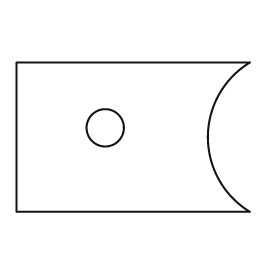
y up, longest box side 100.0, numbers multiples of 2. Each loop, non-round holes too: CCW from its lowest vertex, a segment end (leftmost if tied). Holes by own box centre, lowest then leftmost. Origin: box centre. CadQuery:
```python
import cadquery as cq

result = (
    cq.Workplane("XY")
    .moveTo(-50.0, -32.0)
    .lineTo(50.0, -32.0)
    .threePointArc((32.0, 0.0), (50.0, 32.0))
    .lineTo(-50.0, 32.0)
    .close()
    .moveTo(-12.0, 4.0)
    .circle(8.0)
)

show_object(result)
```